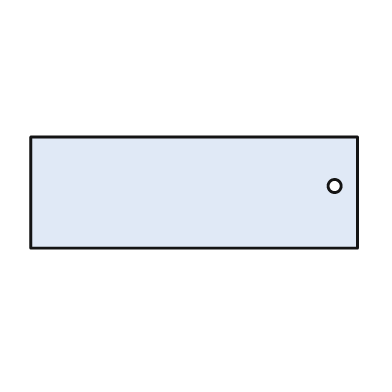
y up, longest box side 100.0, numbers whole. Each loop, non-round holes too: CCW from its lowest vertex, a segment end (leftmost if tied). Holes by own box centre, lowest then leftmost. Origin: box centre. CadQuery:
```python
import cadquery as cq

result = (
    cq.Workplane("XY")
    .moveTo(-50.0, -17.0)
    .lineTo(50.0, -17.0)
    .lineTo(50.0, 17.0)
    .lineTo(-50.0, 17.0)
    .close()
    .moveTo(43.0, 2.0)
    .circle(2.0)
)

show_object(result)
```